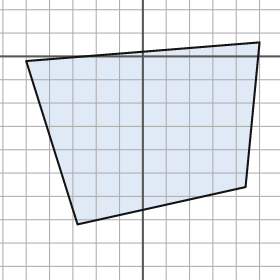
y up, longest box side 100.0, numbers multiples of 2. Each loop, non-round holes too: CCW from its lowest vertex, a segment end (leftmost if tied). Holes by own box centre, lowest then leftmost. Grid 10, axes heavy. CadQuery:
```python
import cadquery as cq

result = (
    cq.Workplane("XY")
    .moveTo(-28.0, -72.0)
    .lineTo(44.0, -56.0)
    .lineTo(50.0, 6.0)
    .lineTo(-50.0, -2.0)
    .close()
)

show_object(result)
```